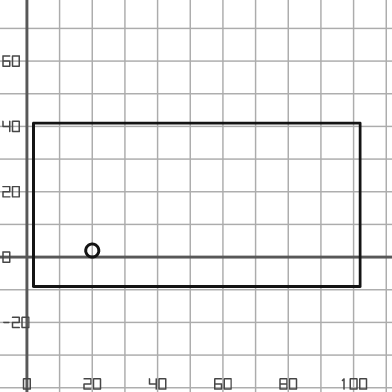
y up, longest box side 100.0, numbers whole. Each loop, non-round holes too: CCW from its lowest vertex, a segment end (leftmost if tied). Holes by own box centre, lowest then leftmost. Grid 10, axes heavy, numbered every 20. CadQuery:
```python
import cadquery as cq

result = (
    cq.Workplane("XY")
    .moveTo(2.0, -9.0)
    .lineTo(102.0, -9.0)
    .lineTo(102.0, 41.0)
    .lineTo(2.0, 41.0)
    .close()
    .moveTo(20.0, 2.0)
    .circle(2.0)
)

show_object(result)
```